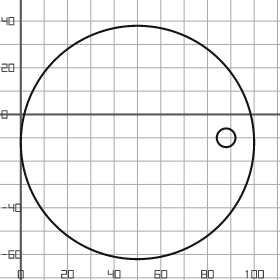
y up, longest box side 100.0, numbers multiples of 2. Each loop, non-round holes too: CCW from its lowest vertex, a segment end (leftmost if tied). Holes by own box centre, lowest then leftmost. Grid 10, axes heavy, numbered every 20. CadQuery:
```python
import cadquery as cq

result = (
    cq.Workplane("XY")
    .moveTo(50.0, -12.0)
    .circle(50.0)
    .moveTo(88.0, -10.0)
    .circle(4.0)
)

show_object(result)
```